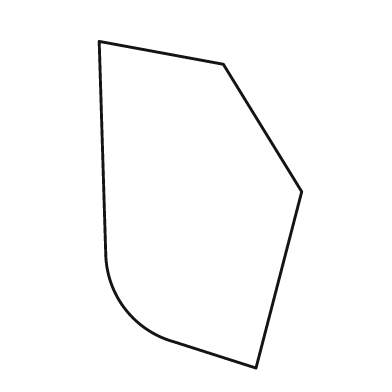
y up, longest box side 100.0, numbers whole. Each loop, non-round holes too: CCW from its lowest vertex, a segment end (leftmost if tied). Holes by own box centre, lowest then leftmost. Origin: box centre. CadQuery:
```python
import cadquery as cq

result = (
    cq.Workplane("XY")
    .moveTo(17.0, -50.0)
    .lineTo(31.0, 4.0)
    .lineTo(7.0, 43.0)
    .lineTo(-31.0, 50.0)
    .lineTo(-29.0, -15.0)
    .threePointArc((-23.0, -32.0), (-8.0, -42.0))
    .close()
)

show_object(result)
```